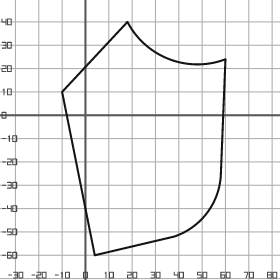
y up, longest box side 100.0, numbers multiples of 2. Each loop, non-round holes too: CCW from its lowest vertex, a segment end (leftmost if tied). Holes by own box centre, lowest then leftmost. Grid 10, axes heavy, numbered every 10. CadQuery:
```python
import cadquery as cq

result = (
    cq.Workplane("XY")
    .moveTo(4.0, -60.0)
    .lineTo(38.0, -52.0)
    .threePointArc((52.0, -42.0), (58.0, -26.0))
    .lineTo(60.0, 24.0)
    .threePointArc((36.0, 24.0), (18.0, 40.0))
    .lineTo(-10.0, 10.0)
    .close()
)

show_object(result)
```